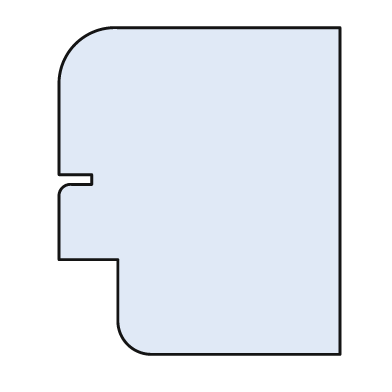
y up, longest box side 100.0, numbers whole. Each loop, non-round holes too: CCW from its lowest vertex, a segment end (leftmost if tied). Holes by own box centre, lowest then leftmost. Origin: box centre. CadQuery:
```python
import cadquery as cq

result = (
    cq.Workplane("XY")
    .moveTo(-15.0, -50.0)
    .lineTo(43.0, -50.0)
    .lineTo(43.0, 50.0)
    .lineTo(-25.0, 50.0)
    .threePointArc((-38.0, 45.0), (-43.0, 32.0))
    .lineTo(-43.0, 5.0)
    .lineTo(-33.0, 5.0)
    .lineTo(-33.0, 2.0)
    .lineTo(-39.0, 2.0)
    .threePointArc((-42.0, 1.0), (-43.0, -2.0))
    .lineTo(-43.0, -21.0)
    .lineTo(-25.0, -21.0)
    .lineTo(-25.0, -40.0)
    .threePointArc((-22.0, -47.0), (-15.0, -50.0))
    .close()
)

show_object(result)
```